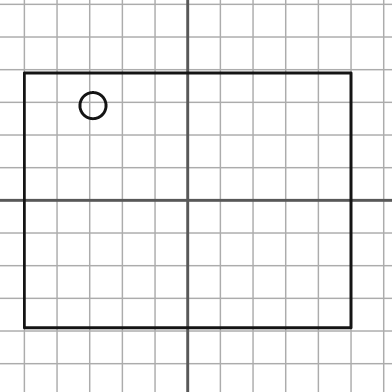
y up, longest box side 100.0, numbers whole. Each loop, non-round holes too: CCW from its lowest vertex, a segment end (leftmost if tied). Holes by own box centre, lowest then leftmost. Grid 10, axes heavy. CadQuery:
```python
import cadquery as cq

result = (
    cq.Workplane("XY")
    .moveTo(-50.0, -39.0)
    .lineTo(50.0, -39.0)
    .lineTo(50.0, 39.0)
    .lineTo(-50.0, 39.0)
    .close()
    .moveTo(-29.0, 29.0)
    .circle(4.0)
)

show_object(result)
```